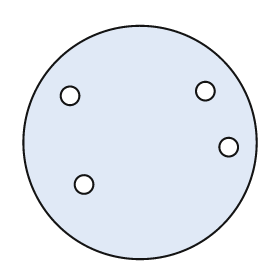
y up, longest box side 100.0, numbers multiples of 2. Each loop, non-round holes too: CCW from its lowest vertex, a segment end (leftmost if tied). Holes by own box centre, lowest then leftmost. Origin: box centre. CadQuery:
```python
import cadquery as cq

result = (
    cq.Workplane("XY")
    .moveTo(0.0, 0.0)
    .circle(50.0)
    .moveTo(-24.0, -18.0)
    .circle(4.0)
    .moveTo(38.0, -2.0)
    .circle(4.0)
    .moveTo(-30.0, 20.0)
    .circle(4.0)
    .moveTo(28.0, 22.0)
    .circle(4.0)
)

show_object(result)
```